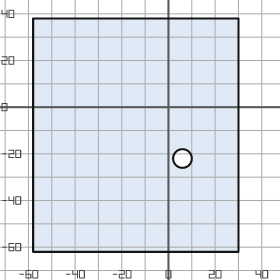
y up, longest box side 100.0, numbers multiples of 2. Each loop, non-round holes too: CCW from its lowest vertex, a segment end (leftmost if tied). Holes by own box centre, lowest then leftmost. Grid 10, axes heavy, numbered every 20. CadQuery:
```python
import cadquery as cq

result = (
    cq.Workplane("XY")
    .moveTo(-58.0, -62.0)
    .lineTo(30.0, -62.0)
    .lineTo(30.0, 38.0)
    .lineTo(-58.0, 38.0)
    .close()
    .moveTo(6.0, -22.0)
    .circle(4.0)
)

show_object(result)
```